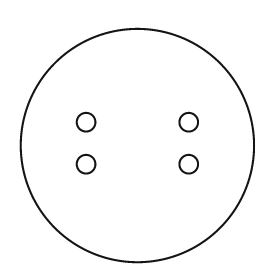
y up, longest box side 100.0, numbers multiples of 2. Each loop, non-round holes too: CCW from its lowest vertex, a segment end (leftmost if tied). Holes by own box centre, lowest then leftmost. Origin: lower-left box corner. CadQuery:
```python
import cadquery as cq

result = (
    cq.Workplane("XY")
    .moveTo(50.0, 50.0)
    .circle(50.0)
    .moveTo(28.0, 42.0)
    .circle(4.0)
    .moveTo(72.0, 42.0)
    .circle(4.0)
    .moveTo(28.0, 60.0)
    .circle(4.0)
    .moveTo(72.0, 60.0)
    .circle(4.0)
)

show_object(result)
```